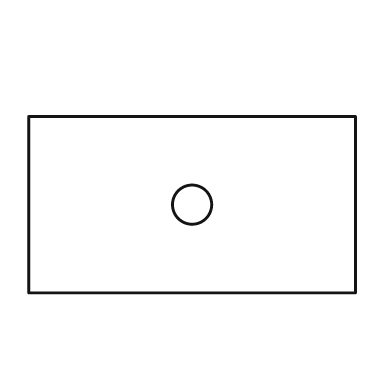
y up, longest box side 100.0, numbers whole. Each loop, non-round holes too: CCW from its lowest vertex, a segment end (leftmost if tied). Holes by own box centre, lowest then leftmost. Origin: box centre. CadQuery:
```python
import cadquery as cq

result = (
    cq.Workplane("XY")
    .moveTo(-50.0, -27.0)
    .lineTo(50.0, -27.0)
    .lineTo(50.0, 27.0)
    .lineTo(-50.0, 27.0)
    .close()
    .moveTo(0.0, 0.0)
    .circle(6.0)
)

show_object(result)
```